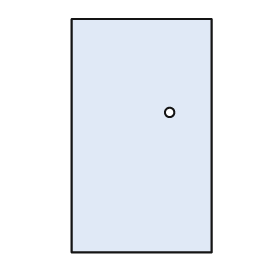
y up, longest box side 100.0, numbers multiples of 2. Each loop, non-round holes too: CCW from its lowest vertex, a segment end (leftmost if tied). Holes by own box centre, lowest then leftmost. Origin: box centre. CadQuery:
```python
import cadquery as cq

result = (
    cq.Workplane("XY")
    .moveTo(-30.0, -50.0)
    .lineTo(30.0, -50.0)
    .lineTo(30.0, 50.0)
    .lineTo(-30.0, 50.0)
    .close()
    .moveTo(12.0, 10.0)
    .circle(2.0)
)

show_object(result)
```